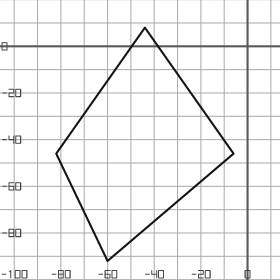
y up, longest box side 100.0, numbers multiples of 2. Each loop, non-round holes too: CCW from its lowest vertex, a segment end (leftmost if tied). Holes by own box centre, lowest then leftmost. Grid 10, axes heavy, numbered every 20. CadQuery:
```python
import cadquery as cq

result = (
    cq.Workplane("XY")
    .moveTo(-60.0, -92.0)
    .lineTo(-6.0, -46.0)
    .lineTo(-44.0, 8.0)
    .lineTo(-82.0, -46.0)
    .close()
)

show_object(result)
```